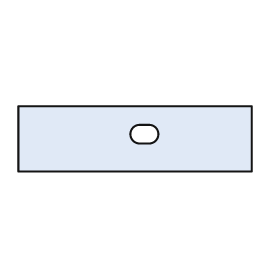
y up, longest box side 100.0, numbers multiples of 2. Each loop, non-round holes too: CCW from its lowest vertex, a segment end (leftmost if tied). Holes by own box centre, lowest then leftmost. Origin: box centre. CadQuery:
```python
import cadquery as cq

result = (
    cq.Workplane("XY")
    .moveTo(-50.0, -14.0)
    .lineTo(50.0, -14.0)
    .lineTo(50.0, 14.0)
    .lineTo(-50.0, 14.0)
    .close()
    .moveTo(2.0, -2.0)
    .lineTo(6.0, -2.0)
    .threePointArc((10.0, 2.0), (6.0, 6.0))
    .lineTo(2.0, 6.0)
    .threePointArc((-2.0, 2.0), (2.0, -2.0))
    .close()
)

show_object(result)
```